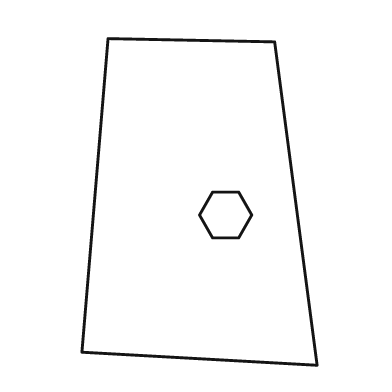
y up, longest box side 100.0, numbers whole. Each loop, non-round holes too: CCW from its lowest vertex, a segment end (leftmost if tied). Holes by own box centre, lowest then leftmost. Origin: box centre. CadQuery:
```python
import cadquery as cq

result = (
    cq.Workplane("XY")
    .moveTo(36.0, -50.0)
    .lineTo(23.0, 49.0)
    .lineTo(-28.0, 50.0)
    .lineTo(-36.0, -46.0)
    .close()
    .moveTo(4.0, -11.0)
    .lineTo(12.0, -11.0)
    .lineTo(16.0, -4.0)
    .lineTo(12.0, 3.0)
    .lineTo(4.0, 3.0)
    .lineTo(0.0, -4.0)
    .close()
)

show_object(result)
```